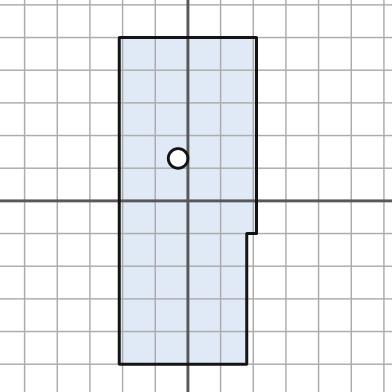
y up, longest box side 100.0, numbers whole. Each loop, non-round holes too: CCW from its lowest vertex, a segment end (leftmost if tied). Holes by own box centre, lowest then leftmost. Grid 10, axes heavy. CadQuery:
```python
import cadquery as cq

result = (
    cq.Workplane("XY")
    .moveTo(-21.0, -50.0)
    .lineTo(18.0, -50.0)
    .lineTo(18.0, -10.0)
    .lineTo(21.0, -10.0)
    .lineTo(21.0, 50.0)
    .lineTo(-21.0, 50.0)
    .close()
    .moveTo(-3.0, 13.0)
    .circle(3.0)
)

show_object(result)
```